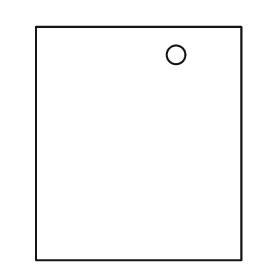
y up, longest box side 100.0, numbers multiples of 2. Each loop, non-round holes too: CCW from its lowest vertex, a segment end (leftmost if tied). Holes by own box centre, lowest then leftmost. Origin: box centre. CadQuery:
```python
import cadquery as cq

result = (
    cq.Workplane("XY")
    .moveTo(-44.0, -50.0)
    .lineTo(44.0, -50.0)
    .lineTo(44.0, 50.0)
    .lineTo(-44.0, 50.0)
    .close()
    .moveTo(16.0, 38.0)
    .circle(4.0)
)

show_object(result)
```